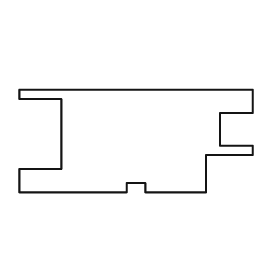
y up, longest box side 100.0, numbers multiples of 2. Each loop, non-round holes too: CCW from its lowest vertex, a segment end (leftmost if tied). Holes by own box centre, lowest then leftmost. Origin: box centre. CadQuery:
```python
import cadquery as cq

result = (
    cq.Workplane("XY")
    .moveTo(-50.0, -22.0)
    .lineTo(-4.0, -22.0)
    .lineTo(-4.0, -18.0)
    .lineTo(4.0, -18.0)
    .lineTo(4.0, -22.0)
    .lineTo(30.0, -22.0)
    .lineTo(30.0, -6.0)
    .lineTo(50.0, -6.0)
    .lineTo(50.0, -2.0)
    .lineTo(36.0, -2.0)
    .lineTo(36.0, 12.0)
    .lineTo(50.0, 12.0)
    .lineTo(50.0, 22.0)
    .lineTo(-50.0, 22.0)
    .lineTo(-50.0, 18.0)
    .lineTo(-32.0, 18.0)
    .lineTo(-32.0, -12.0)
    .lineTo(-50.0, -12.0)
    .close()
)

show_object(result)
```